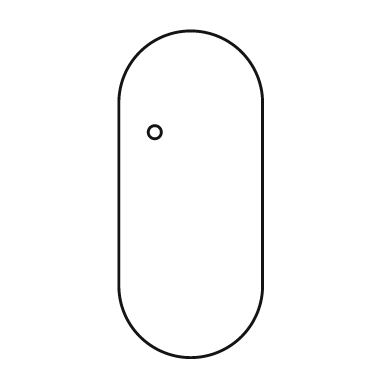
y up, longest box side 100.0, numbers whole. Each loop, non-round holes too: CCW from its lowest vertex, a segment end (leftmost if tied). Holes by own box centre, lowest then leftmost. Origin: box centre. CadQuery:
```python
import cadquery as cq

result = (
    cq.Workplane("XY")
    .moveTo(-22.0, -28.0)
    .threePointArc((0.0, -50.0), (22.0, -28.0))
    .lineTo(22.0, 28.0)
    .threePointArc((0.0, 50.0), (-22.0, 28.0))
    .close()
    .moveTo(-11.0, 19.0)
    .circle(2.0)
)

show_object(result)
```